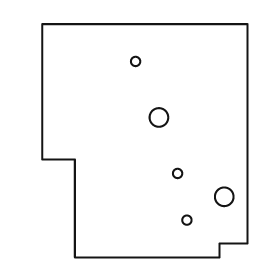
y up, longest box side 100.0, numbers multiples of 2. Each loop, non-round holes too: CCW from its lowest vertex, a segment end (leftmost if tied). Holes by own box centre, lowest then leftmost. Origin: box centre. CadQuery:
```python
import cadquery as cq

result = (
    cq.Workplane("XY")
    .moveTo(-30.0, -50.0)
    .lineTo(32.0, -50.0)
    .lineTo(32.0, -44.0)
    .lineTo(44.0, -44.0)
    .lineTo(44.0, 50.0)
    .lineTo(-44.0, 50.0)
    .lineTo(-44.0, -8.0)
    .lineTo(-30.0, -8.0)
    .close()
    .moveTo(18.0, -34.0)
    .circle(2.0)
    .moveTo(34.0, -24.0)
    .circle(4.0)
    .moveTo(14.0, -14.0)
    .circle(2.0)
    .moveTo(6.0, 10.0)
    .circle(4.0)
    .moveTo(-4.0, 34.0)
    .circle(2.0)
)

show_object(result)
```